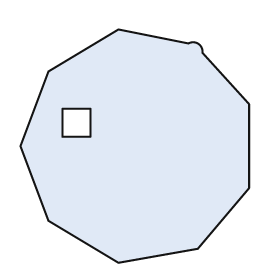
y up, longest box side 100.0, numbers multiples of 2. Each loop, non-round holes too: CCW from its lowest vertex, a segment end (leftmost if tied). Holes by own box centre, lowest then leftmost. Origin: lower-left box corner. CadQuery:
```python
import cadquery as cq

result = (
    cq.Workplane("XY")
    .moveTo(42.0, 0.0)
    .lineTo(76.0, 6.0)
    .lineTo(98.0, 32.0)
    .lineTo(98.0, 68.0)
    .lineTo(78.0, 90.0)
    .threePointArc((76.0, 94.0), (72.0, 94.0))
    .lineTo(42.0, 100.0)
    .lineTo(12.0, 82.0)
    .lineTo(0.0, 50.0)
    .lineTo(12.0, 18.0)
    .close()
    .moveTo(18.0, 54.0)
    .lineTo(30.0, 54.0)
    .lineTo(30.0, 66.0)
    .lineTo(18.0, 66.0)
    .close()
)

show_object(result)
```